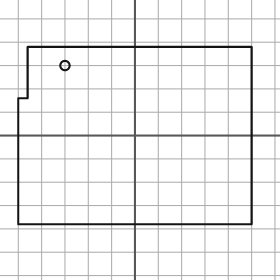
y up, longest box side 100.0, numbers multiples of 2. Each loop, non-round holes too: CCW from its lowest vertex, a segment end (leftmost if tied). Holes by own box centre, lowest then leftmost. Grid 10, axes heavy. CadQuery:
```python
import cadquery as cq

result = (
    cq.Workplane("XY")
    .moveTo(-50.0, -38.0)
    .lineTo(50.0, -38.0)
    .lineTo(50.0, 38.0)
    .lineTo(-46.0, 38.0)
    .lineTo(-46.0, 16.0)
    .lineTo(-50.0, 16.0)
    .close()
    .moveTo(-30.0, 30.0)
    .circle(2.0)
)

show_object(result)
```